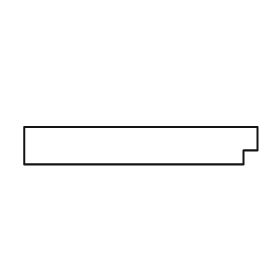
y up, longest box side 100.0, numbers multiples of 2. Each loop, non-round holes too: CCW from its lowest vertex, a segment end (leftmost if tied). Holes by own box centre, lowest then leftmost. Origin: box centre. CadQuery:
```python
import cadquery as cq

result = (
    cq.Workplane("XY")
    .moveTo(-50.0, -8.0)
    .lineTo(44.0, -8.0)
    .lineTo(44.0, -2.0)
    .lineTo(50.0, -2.0)
    .lineTo(50.0, 8.0)
    .lineTo(-50.0, 8.0)
    .close()
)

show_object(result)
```